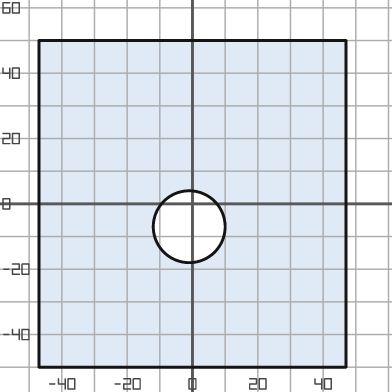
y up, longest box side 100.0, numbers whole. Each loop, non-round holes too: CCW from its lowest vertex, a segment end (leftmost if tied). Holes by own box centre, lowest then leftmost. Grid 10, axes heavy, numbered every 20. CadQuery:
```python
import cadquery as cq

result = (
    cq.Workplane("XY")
    .moveTo(-47.0, -50.0)
    .lineTo(47.0, -50.0)
    .lineTo(47.0, 50.0)
    .lineTo(-47.0, 50.0)
    .close()
    .moveTo(-1.0, -7.0)
    .circle(11.0)
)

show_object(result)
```